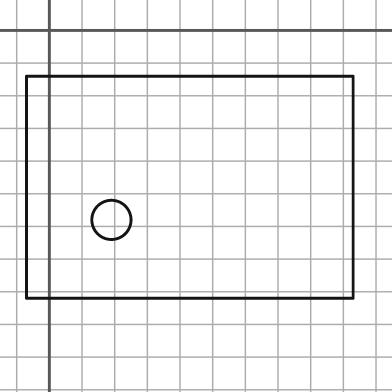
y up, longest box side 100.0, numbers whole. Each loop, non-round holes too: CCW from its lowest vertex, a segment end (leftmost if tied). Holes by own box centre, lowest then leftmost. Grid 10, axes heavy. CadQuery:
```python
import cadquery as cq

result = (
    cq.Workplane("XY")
    .moveTo(-7.0, -82.0)
    .lineTo(93.0, -82.0)
    .lineTo(93.0, -14.0)
    .lineTo(-7.0, -14.0)
    .close()
    .moveTo(19.0, -58.0)
    .circle(6.0)
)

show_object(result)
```